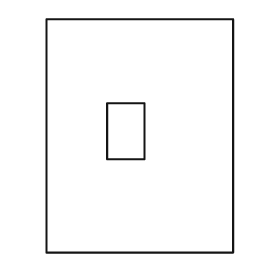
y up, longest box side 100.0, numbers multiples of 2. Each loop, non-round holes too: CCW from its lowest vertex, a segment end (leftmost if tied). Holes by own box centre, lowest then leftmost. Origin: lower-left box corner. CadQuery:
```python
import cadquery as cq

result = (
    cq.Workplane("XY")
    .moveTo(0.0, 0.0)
    .lineTo(80.0, 0.0)
    .lineTo(80.0, 100.0)
    .lineTo(0.0, 100.0)
    .close()
    .moveTo(26.0, 40.0)
    .lineTo(42.0, 40.0)
    .lineTo(42.0, 64.0)
    .lineTo(26.0, 64.0)
    .close()
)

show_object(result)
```